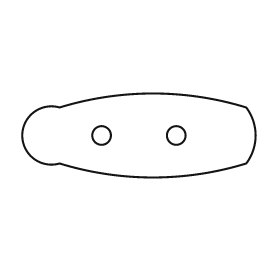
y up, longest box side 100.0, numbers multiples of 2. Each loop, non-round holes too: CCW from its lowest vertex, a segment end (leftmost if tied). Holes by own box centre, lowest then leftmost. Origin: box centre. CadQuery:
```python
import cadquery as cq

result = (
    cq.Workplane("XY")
    .moveTo(-34.0, -12.0)
    .threePointArc((6.0, -18.0), (46.0, -12.0))
    .threePointArc((50.0, 0.0), (46.0, 12.0))
    .threePointArc((6.0, 18.0), (-34.0, 12.0))
    .threePointArc((-50.0, 0.0), (-34.0, -12.0))
    .close()
    .moveTo(-16.0, 0.0)
    .circle(4.0)
    .moveTo(16.0, 0.0)
    .circle(4.0)
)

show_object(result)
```